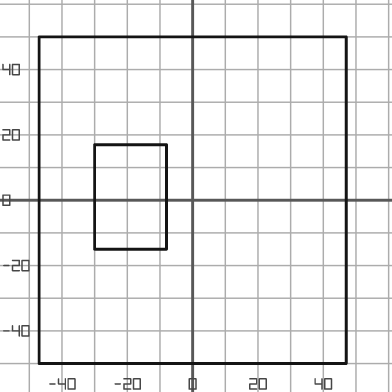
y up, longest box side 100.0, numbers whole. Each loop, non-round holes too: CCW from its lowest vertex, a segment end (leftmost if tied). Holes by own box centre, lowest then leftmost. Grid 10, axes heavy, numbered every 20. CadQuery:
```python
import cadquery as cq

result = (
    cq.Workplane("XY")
    .moveTo(-47.0, -50.0)
    .lineTo(47.0, -50.0)
    .lineTo(47.0, 50.0)
    .lineTo(-47.0, 50.0)
    .close()
    .moveTo(-30.0, -15.0)
    .lineTo(-8.0, -15.0)
    .lineTo(-8.0, 17.0)
    .lineTo(-30.0, 17.0)
    .close()
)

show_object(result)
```